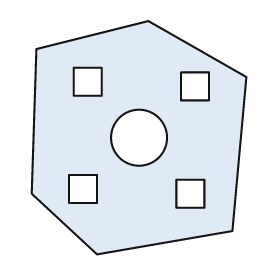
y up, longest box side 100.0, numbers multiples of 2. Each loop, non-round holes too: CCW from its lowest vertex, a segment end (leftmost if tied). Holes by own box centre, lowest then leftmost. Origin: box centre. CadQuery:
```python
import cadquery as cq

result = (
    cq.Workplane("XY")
    .moveTo(-18.0, -50.0)
    .lineTo(40.0, -40.0)
    .lineTo(46.0, 26.0)
    .lineTo(4.0, 50.0)
    .lineTo(-44.0, 38.0)
    .lineTo(-46.0, -24.0)
    .close()
    .moveTo(16.0, -30.0)
    .lineTo(28.0, -30.0)
    .lineTo(28.0, -18.0)
    .lineTo(16.0, -18.0)
    .close()
    .moveTo(-30.0, -28.0)
    .lineTo(-18.0, -28.0)
    .lineTo(-18.0, -16.0)
    .lineTo(-30.0, -16.0)
    .close()
    .moveTo(0.0, 0.0)
    .circle(12.0)
    .moveTo(18.0, 16.0)
    .lineTo(30.0, 16.0)
    .lineTo(30.0, 28.0)
    .lineTo(18.0, 28.0)
    .close()
    .moveTo(-28.0, 18.0)
    .lineTo(-16.0, 18.0)
    .lineTo(-16.0, 30.0)
    .lineTo(-28.0, 30.0)
    .close()
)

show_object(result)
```